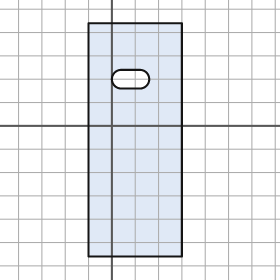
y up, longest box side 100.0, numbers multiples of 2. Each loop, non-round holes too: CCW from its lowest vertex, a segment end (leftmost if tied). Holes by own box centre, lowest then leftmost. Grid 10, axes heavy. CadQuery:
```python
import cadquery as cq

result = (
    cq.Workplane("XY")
    .moveTo(-10.0, -56.0)
    .lineTo(30.0, -56.0)
    .lineTo(30.0, 44.0)
    .lineTo(-10.0, 44.0)
    .close()
    .moveTo(4.0, 16.0)
    .lineTo(12.0, 16.0)
    .threePointArc((16.0, 20.0), (12.0, 24.0))
    .lineTo(4.0, 24.0)
    .threePointArc((0.0, 20.0), (4.0, 16.0))
    .close()
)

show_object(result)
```